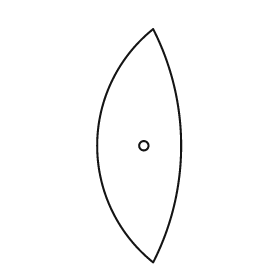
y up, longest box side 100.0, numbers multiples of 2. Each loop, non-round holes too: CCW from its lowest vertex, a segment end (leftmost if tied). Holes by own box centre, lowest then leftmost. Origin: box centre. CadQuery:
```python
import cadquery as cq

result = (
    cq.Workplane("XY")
    .moveTo(6.0, -50.0)
    .threePointArc((18.0, 0.0), (6.0, 50.0))
    .threePointArc((-18.0, 0.0), (6.0, -50.0))
    .close()
    .moveTo(2.0, 0.0)
    .circle(2.0)
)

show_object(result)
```